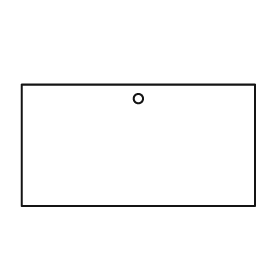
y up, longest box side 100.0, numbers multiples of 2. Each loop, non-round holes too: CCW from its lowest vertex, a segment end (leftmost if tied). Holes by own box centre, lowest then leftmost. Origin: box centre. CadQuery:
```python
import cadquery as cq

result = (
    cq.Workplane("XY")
    .moveTo(-50.0, -26.0)
    .lineTo(50.0, -26.0)
    .lineTo(50.0, 26.0)
    .lineTo(-50.0, 26.0)
    .close()
    .moveTo(0.0, 20.0)
    .circle(2.0)
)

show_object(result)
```